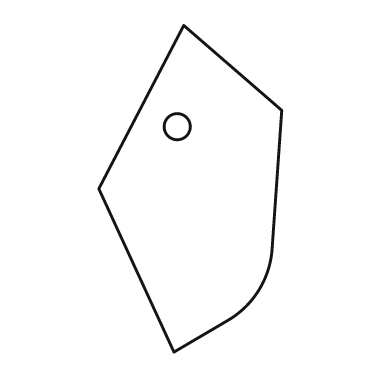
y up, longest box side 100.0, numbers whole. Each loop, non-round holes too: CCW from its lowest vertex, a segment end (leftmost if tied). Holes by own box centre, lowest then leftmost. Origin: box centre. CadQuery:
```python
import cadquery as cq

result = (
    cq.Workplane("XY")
    .moveTo(-5.0, -50.0)
    .lineTo(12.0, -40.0)
    .threePointArc((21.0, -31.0), (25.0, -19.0))
    .lineTo(28.0, 24.0)
    .lineTo(-2.0, 50.0)
    .lineTo(-28.0, 0.0)
    .close()
    .moveTo(-4.0, 19.0)
    .circle(4.0)
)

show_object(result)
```